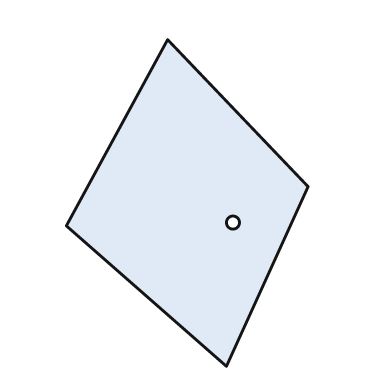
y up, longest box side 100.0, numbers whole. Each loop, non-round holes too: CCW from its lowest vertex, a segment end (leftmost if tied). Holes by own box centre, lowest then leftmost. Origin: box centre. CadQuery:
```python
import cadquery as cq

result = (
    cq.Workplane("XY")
    .moveTo(12.0, -50.0)
    .lineTo(37.0, 5.0)
    .lineTo(-6.0, 50.0)
    .lineTo(-37.0, -7.0)
    .close()
    .moveTo(14.0, -6.0)
    .circle(2.0)
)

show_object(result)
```